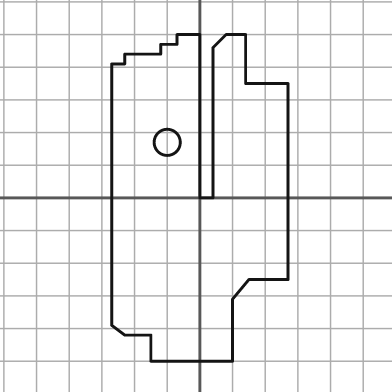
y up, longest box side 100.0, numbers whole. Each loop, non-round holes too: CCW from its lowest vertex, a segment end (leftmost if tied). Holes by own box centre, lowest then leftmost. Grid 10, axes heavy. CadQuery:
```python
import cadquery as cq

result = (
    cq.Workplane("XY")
    .moveTo(-15.0, -50.0)
    .lineTo(10.0, -50.0)
    .lineTo(10.0, -31.0)
    .lineTo(15.0, -25.0)
    .lineTo(27.0, -25.0)
    .lineTo(27.0, 35.0)
    .lineTo(14.0, 35.0)
    .lineTo(14.0, 50.0)
    .lineTo(8.0, 50.0)
    .lineTo(4.0, 46.0)
    .lineTo(4.0, 0.0)
    .lineTo(0.0, 0.0)
    .lineTo(0.0, 50.0)
    .lineTo(-7.0, 50.0)
    .lineTo(-7.0, 47.0)
    .lineTo(-12.0, 47.0)
    .lineTo(-12.0, 44.0)
    .lineTo(-23.0, 44.0)
    .lineTo(-23.0, 41.0)
    .lineTo(-27.0, 41.0)
    .lineTo(-27.0, -39.0)
    .lineTo(-23.0, -42.0)
    .lineTo(-15.0, -42.0)
    .close()
    .moveTo(-10.0, 17.0)
    .circle(4.0)
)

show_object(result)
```